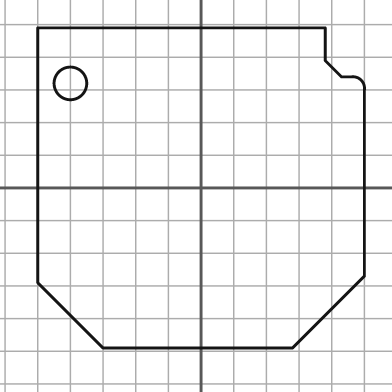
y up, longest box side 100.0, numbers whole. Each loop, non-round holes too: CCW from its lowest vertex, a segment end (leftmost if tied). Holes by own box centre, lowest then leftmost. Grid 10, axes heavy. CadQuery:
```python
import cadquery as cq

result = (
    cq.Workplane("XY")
    .moveTo(-30.0, -49.0)
    .lineTo(28.0, -49.0)
    .lineTo(50.0, -27.0)
    .lineTo(50.0, 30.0)
    .threePointArc((49.0, 33.0), (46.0, 34.0))
    .lineTo(43.0, 34.0)
    .lineTo(38.0, 39.0)
    .lineTo(38.0, 49.0)
    .lineTo(-50.0, 49.0)
    .lineTo(-50.0, -29.0)
    .close()
    .moveTo(-40.0, 32.0)
    .circle(5.0)
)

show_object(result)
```